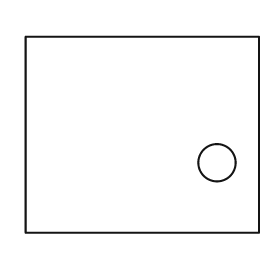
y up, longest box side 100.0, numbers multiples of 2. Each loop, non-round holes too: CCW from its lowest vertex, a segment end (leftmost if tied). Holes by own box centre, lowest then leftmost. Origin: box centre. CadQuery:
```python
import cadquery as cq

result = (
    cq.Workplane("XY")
    .moveTo(-50.0, -42.0)
    .lineTo(50.0, -42.0)
    .lineTo(50.0, 42.0)
    .lineTo(-50.0, 42.0)
    .close()
    .moveTo(32.0, -12.0)
    .circle(8.0)
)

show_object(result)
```